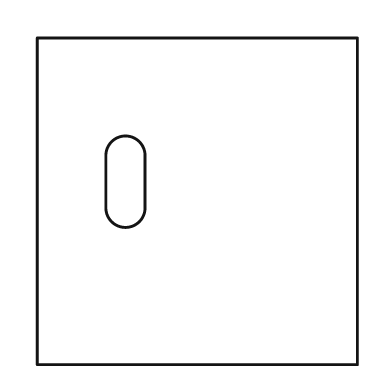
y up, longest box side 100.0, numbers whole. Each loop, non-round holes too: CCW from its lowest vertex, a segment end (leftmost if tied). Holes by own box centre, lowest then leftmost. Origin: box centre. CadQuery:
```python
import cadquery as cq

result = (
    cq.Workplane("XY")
    .moveTo(-49.0, -50.0)
    .lineTo(49.0, -50.0)
    .lineTo(49.0, 50.0)
    .lineTo(-49.0, 50.0)
    .close()
    .moveTo(-28.0, -2.0)
    .threePointArc((-22.0, -8.0), (-16.0, -2.0))
    .lineTo(-16.0, 14.0)
    .threePointArc((-22.0, 20.0), (-28.0, 14.0))
    .close()
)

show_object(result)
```